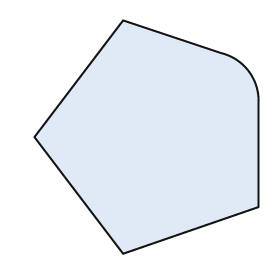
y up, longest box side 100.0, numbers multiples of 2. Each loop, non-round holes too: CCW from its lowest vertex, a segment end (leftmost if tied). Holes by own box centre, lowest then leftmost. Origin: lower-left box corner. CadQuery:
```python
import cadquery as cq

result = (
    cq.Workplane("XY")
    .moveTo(38.0, 0.0)
    .lineTo(96.0, 20.0)
    .lineTo(96.0, 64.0)
    .threePointArc((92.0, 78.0), (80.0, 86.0))
    .lineTo(38.0, 100.0)
    .lineTo(0.0, 50.0)
    .close()
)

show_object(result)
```